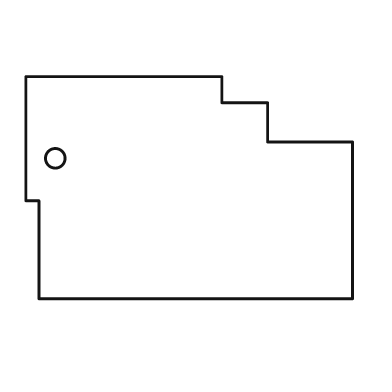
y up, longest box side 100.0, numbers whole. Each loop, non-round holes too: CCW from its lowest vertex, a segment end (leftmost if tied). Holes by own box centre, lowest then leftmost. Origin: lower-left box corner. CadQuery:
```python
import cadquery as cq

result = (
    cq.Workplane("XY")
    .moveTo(4.0, 0.0)
    .lineTo(100.0, 0.0)
    .lineTo(100.0, 48.0)
    .lineTo(74.0, 48.0)
    .lineTo(74.0, 60.0)
    .lineTo(60.0, 60.0)
    .lineTo(60.0, 68.0)
    .lineTo(0.0, 68.0)
    .lineTo(0.0, 30.0)
    .lineTo(4.0, 30.0)
    .close()
    .moveTo(9.0, 43.0)
    .circle(3.0)
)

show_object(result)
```